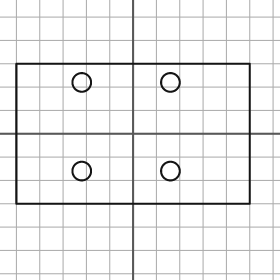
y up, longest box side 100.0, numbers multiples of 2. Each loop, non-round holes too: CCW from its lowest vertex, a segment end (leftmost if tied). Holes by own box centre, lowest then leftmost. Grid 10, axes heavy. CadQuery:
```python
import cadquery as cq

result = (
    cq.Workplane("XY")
    .moveTo(-50.0, -30.0)
    .lineTo(50.0, -30.0)
    .lineTo(50.0, 30.0)
    .lineTo(-50.0, 30.0)
    .close()
    .moveTo(-22.0, -16.0)
    .circle(4.0)
    .moveTo(16.0, -16.0)
    .circle(4.0)
    .moveTo(-22.0, 22.0)
    .circle(4.0)
    .moveTo(16.0, 22.0)
    .circle(4.0)
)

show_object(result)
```